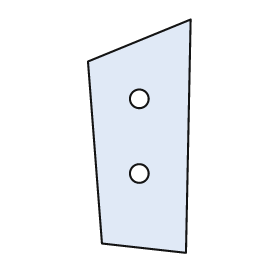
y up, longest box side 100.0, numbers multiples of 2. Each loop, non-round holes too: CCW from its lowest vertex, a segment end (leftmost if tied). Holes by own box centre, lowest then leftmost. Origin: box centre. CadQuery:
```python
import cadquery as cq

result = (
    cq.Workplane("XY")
    .moveTo(20.0, -50.0)
    .lineTo(22.0, 50.0)
    .lineTo(-22.0, 32.0)
    .lineTo(-16.0, -46.0)
    .close()
    .moveTo(0.0, -16.0)
    .circle(4.0)
    .moveTo(0.0, 16.0)
    .circle(4.0)
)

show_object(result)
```